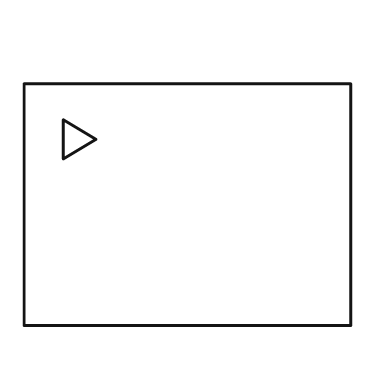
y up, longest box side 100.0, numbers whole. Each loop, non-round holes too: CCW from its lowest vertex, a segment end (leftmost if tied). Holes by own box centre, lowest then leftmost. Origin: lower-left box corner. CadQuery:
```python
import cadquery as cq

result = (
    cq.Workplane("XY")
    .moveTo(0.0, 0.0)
    .lineTo(100.0, 0.0)
    .lineTo(100.0, 74.0)
    .lineTo(0.0, 74.0)
    .close()
    .moveTo(12.0, 51.0)
    .lineTo(22.0, 57.0)
    .lineTo(12.0, 63.0)
    .close()
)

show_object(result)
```